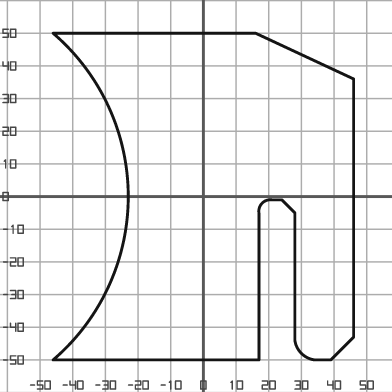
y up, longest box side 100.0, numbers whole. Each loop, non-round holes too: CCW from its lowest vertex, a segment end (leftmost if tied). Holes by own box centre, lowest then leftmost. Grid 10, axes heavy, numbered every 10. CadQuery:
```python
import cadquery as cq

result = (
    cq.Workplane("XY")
    .moveTo(-46.0, -50.0)
    .lineTo(17.0, -50.0)
    .lineTo(17.0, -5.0)
    .threePointArc((18.0, -2.0), (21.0, -1.0))
    .lineTo(24.0, -1.0)
    .lineTo(28.0, -5.0)
    .lineTo(28.0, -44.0)
    .threePointArc((30.0, -48.0), (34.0, -50.0))
    .lineTo(39.0, -50.0)
    .lineTo(46.0, -43.0)
    .lineTo(46.0, 36.0)
    .lineTo(16.0, 50.0)
    .lineTo(-46.0, 50.0)
    .threePointArc((-23.0, 0.0), (-46.0, -50.0))
    .close()
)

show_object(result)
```